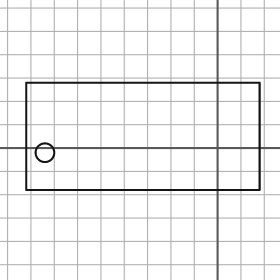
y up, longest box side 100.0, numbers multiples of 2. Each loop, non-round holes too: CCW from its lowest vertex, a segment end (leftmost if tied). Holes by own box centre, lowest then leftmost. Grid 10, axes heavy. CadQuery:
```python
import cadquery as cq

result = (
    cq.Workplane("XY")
    .moveTo(-82.0, -18.0)
    .lineTo(18.0, -18.0)
    .lineTo(18.0, 28.0)
    .lineTo(-82.0, 28.0)
    .close()
    .moveTo(-74.0, -2.0)
    .circle(4.0)
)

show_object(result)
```